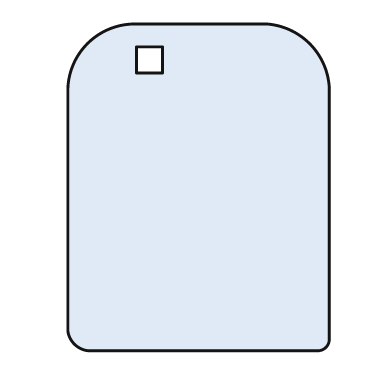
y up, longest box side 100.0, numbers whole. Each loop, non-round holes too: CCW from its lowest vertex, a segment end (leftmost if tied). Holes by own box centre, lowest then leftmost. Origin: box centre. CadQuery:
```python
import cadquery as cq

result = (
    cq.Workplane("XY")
    .moveTo(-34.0, -50.0)
    .lineTo(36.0, -50.0)
    .threePointArc((39.0, -49.0), (40.0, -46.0))
    .lineTo(40.0, 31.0)
    .threePointArc((34.0, 44.0), (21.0, 50.0))
    .lineTo(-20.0, 50.0)
    .threePointArc((-34.0, 44.0), (-40.0, 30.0))
    .lineTo(-40.0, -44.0)
    .threePointArc((-38.0, -48.0), (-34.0, -50.0))
    .close()
    .moveTo(-19.0, 35.0)
    .lineTo(-11.0, 35.0)
    .lineTo(-11.0, 43.0)
    .lineTo(-19.0, 43.0)
    .close()
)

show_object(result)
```